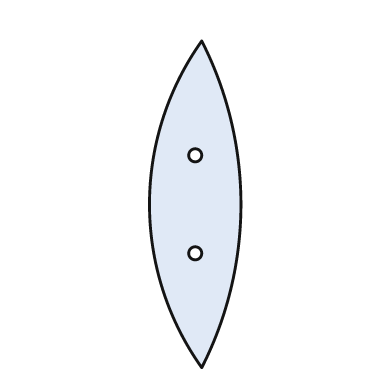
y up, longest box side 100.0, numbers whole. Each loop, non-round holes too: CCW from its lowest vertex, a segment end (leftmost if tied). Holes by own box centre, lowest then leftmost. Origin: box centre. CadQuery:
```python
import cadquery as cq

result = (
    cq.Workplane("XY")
    .moveTo(2.0, -50.0)
    .threePointArc((14.0, 0.0), (2.0, 50.0))
    .threePointArc((-14.0, 0.0), (2.0, -50.0))
    .close()
    .moveTo(0.0, -15.0)
    .circle(2.0)
    .moveTo(0.0, 15.0)
    .circle(2.0)
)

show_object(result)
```